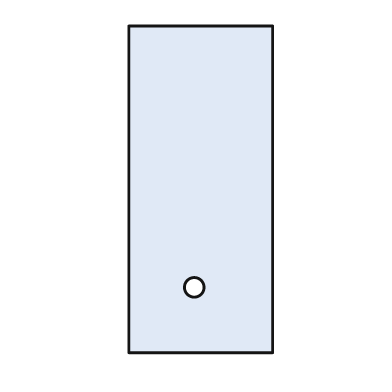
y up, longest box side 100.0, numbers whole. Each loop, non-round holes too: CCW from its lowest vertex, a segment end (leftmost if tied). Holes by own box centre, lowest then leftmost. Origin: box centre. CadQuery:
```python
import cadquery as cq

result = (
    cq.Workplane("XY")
    .moveTo(-22.0, -50.0)
    .lineTo(22.0, -50.0)
    .lineTo(22.0, 50.0)
    .lineTo(-22.0, 50.0)
    .close()
    .moveTo(-2.0, -30.0)
    .circle(3.0)
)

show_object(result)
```